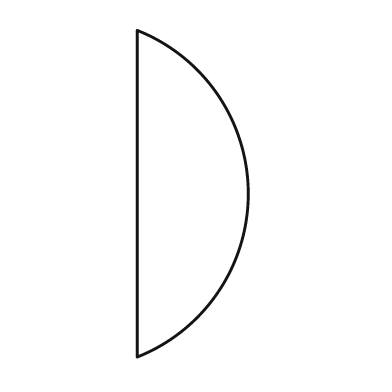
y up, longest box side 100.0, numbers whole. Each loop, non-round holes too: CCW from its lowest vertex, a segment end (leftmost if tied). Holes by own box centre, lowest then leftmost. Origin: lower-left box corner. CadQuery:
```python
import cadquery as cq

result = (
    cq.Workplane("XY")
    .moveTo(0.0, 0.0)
    .threePointArc((34.0, 50.0), (0.0, 100.0))
    .close()
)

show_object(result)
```